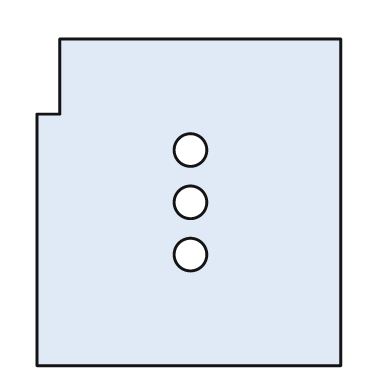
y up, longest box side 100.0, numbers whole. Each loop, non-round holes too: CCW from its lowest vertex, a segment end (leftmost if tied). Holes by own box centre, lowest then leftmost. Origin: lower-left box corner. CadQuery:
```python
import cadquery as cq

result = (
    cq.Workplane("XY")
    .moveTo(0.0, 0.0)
    .lineTo(93.0, 0.0)
    .lineTo(93.0, 100.0)
    .lineTo(7.0, 100.0)
    .lineTo(7.0, 77.0)
    .lineTo(0.0, 77.0)
    .close()
    .moveTo(47.0, 34.0)
    .circle(5.0)
    .moveTo(47.0, 50.0)
    .circle(5.0)
    .moveTo(47.0, 66.0)
    .circle(5.0)
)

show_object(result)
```